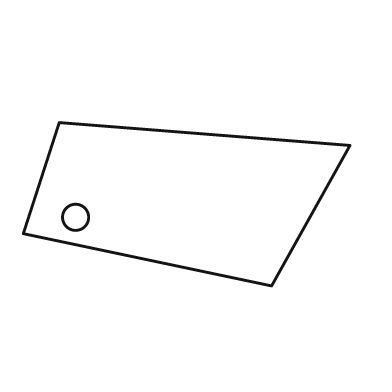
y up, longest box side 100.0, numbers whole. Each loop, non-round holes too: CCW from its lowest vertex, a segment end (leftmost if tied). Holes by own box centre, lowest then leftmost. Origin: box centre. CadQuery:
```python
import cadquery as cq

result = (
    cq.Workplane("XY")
    .moveTo(26.0, -25.0)
    .lineTo(50.0, 18.0)
    .lineTo(-39.0, 25.0)
    .lineTo(-50.0, -9.0)
    .close()
    .moveTo(-34.0, -4.0)
    .circle(4.0)
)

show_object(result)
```